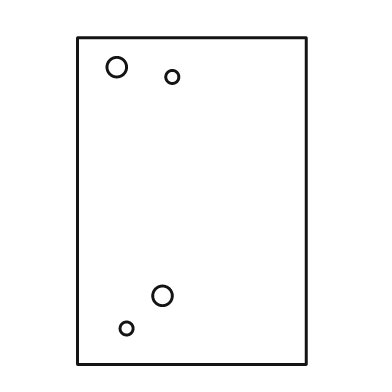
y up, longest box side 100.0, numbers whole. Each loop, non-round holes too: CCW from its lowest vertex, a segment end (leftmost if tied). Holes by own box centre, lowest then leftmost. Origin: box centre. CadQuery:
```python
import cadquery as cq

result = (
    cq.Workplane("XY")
    .moveTo(-35.0, -50.0)
    .lineTo(35.0, -50.0)
    .lineTo(35.0, 50.0)
    .lineTo(-35.0, 50.0)
    .close()
    .moveTo(-20.0, -39.0)
    .circle(2.0)
    .moveTo(-9.0, -29.0)
    .circle(3.0)
    .moveTo(-6.0, 38.0)
    .circle(2.0)
    .moveTo(-23.0, 41.0)
    .circle(3.0)
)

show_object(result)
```